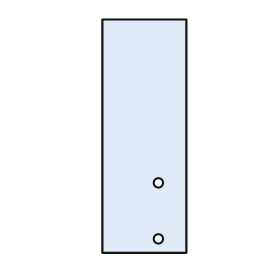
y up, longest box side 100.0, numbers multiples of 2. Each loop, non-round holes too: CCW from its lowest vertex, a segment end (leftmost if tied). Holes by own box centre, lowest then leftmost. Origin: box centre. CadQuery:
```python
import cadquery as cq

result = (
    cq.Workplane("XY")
    .moveTo(-18.0, -50.0)
    .lineTo(18.0, -50.0)
    .lineTo(18.0, 50.0)
    .lineTo(-18.0, 50.0)
    .close()
    .moveTo(6.0, -44.0)
    .circle(2.0)
    .moveTo(6.0, -20.0)
    .circle(2.0)
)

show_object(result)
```